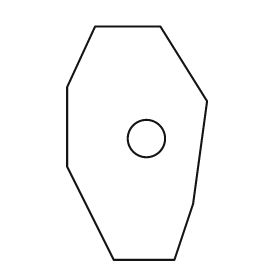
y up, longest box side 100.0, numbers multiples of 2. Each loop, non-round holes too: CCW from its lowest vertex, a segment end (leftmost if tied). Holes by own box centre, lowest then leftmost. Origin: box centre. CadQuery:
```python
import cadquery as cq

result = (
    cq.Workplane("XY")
    .moveTo(-10.0, -50.0)
    .lineTo(16.0, -50.0)
    .lineTo(24.0, -26.0)
    .lineTo(30.0, 18.0)
    .lineTo(10.0, 50.0)
    .lineTo(-18.0, 50.0)
    .lineTo(-30.0, 24.0)
    .lineTo(-30.0, -10.0)
    .close()
    .moveTo(4.0, 2.0)
    .circle(8.0)
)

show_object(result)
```